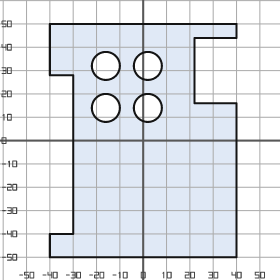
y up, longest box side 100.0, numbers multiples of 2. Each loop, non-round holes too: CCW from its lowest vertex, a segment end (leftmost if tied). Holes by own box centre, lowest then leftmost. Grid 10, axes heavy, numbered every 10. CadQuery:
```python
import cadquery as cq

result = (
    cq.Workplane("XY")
    .moveTo(-40.0, -50.0)
    .lineTo(40.0, -50.0)
    .lineTo(40.0, 16.0)
    .lineTo(22.0, 16.0)
    .lineTo(22.0, 44.0)
    .lineTo(40.0, 44.0)
    .lineTo(40.0, 50.0)
    .lineTo(-40.0, 50.0)
    .lineTo(-40.0, 28.0)
    .lineTo(-30.0, 28.0)
    .lineTo(-30.0, -40.0)
    .lineTo(-40.0, -40.0)
    .close()
    .moveTo(-16.0, 14.0)
    .circle(6.0)
    .moveTo(2.0, 14.0)
    .circle(6.0)
    .moveTo(-16.0, 32.0)
    .circle(6.0)
    .moveTo(2.0, 32.0)
    .circle(6.0)
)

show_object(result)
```